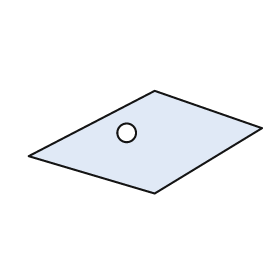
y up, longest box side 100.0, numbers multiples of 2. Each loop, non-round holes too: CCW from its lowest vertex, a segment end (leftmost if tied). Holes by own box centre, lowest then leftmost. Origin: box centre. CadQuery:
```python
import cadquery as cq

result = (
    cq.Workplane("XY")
    .moveTo(4.0, -22.0)
    .lineTo(50.0, 6.0)
    .lineTo(4.0, 22.0)
    .lineTo(-50.0, -6.0)
    .close()
    .moveTo(-8.0, 4.0)
    .circle(4.0)
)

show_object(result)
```